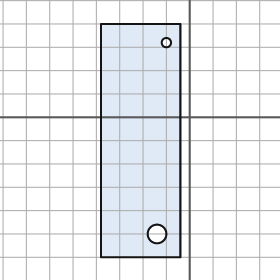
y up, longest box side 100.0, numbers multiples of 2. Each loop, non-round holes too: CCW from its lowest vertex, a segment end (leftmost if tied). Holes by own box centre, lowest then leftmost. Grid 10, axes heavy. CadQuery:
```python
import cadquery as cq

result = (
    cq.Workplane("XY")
    .moveTo(-38.0, -60.0)
    .lineTo(-4.0, -60.0)
    .lineTo(-4.0, 40.0)
    .lineTo(-38.0, 40.0)
    .close()
    .moveTo(-14.0, -50.0)
    .circle(4.0)
    .moveTo(-10.0, 32.0)
    .circle(2.0)
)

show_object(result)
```